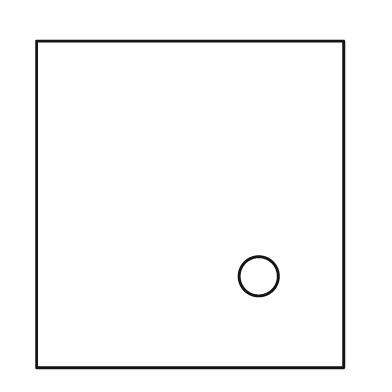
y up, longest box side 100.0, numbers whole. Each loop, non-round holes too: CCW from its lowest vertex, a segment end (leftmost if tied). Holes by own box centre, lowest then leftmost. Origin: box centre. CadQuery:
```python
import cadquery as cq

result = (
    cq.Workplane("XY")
    .moveTo(-47.0, -50.0)
    .lineTo(47.0, -50.0)
    .lineTo(47.0, 50.0)
    .lineTo(-47.0, 50.0)
    .close()
    .moveTo(21.0, -22.0)
    .circle(6.0)
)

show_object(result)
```